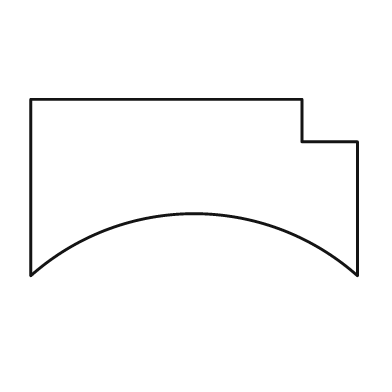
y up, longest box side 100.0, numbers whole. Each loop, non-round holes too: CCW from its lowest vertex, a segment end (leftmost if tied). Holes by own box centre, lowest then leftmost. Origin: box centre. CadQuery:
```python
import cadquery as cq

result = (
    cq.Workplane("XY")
    .moveTo(-50.0, -27.0)
    .threePointArc((0.0, -8.0), (50.0, -27.0))
    .lineTo(50.0, 14.0)
    .lineTo(33.0, 14.0)
    .lineTo(33.0, 27.0)
    .lineTo(-50.0, 27.0)
    .close()
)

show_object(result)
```